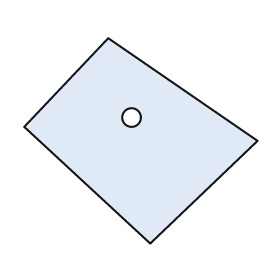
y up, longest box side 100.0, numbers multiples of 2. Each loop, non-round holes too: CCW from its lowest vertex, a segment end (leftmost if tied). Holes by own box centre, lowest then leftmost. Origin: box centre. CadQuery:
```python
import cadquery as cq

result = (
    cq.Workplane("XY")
    .moveTo(4.0, -44.0)
    .lineTo(50.0, 0.0)
    .lineTo(-14.0, 44.0)
    .lineTo(-50.0, 6.0)
    .close()
    .moveTo(-4.0, 10.0)
    .circle(4.0)
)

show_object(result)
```